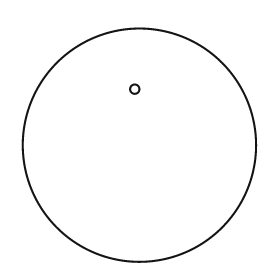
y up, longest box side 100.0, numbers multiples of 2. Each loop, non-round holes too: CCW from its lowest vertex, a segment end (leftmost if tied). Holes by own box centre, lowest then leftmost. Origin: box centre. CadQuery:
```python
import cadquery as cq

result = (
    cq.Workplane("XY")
    .moveTo(0.0, 0.0)
    .circle(50.0)
    .moveTo(-2.0, 24.0)
    .circle(2.0)
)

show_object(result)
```